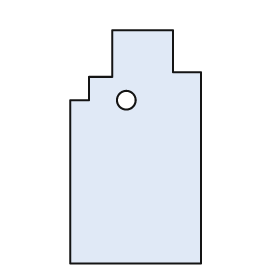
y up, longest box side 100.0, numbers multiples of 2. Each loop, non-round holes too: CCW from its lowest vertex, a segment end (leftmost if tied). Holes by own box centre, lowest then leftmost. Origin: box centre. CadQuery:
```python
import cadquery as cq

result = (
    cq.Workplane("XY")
    .moveTo(-28.0, -50.0)
    .lineTo(28.0, -50.0)
    .lineTo(28.0, 32.0)
    .lineTo(16.0, 32.0)
    .lineTo(16.0, 50.0)
    .lineTo(-10.0, 50.0)
    .lineTo(-10.0, 30.0)
    .lineTo(-20.0, 30.0)
    .lineTo(-20.0, 20.0)
    .lineTo(-28.0, 20.0)
    .close()
    .moveTo(-4.0, 20.0)
    .circle(4.0)
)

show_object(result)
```